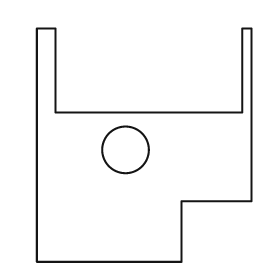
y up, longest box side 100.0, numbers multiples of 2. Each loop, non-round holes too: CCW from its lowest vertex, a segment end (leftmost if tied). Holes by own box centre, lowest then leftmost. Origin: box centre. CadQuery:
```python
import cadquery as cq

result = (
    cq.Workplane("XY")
    .moveTo(-46.0, -50.0)
    .lineTo(16.0, -50.0)
    .lineTo(16.0, -24.0)
    .lineTo(46.0, -24.0)
    .lineTo(46.0, 50.0)
    .lineTo(42.0, 50.0)
    .lineTo(42.0, 14.0)
    .lineTo(-38.0, 14.0)
    .lineTo(-38.0, 50.0)
    .lineTo(-46.0, 50.0)
    .close()
    .moveTo(-8.0, -2.0)
    .circle(10.0)
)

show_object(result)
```